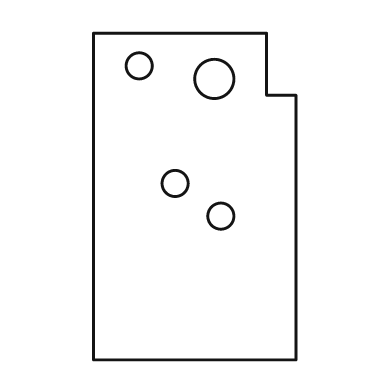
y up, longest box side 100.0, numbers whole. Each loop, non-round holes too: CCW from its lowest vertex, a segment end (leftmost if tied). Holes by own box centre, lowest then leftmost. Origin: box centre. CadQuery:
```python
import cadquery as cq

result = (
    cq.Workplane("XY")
    .moveTo(-31.0, -50.0)
    .lineTo(31.0, -50.0)
    .lineTo(31.0, 31.0)
    .lineTo(22.0, 31.0)
    .lineTo(22.0, 50.0)
    .lineTo(-31.0, 50.0)
    .close()
    .moveTo(8.0, -6.0)
    .circle(4.0)
    .moveTo(-6.0, 4.0)
    .circle(4.0)
    .moveTo(6.0, 36.0)
    .circle(6.0)
    .moveTo(-17.0, 40.0)
    .circle(4.0)
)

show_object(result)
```